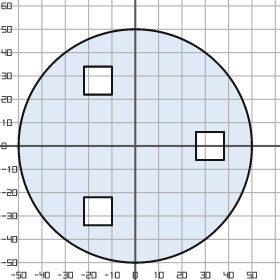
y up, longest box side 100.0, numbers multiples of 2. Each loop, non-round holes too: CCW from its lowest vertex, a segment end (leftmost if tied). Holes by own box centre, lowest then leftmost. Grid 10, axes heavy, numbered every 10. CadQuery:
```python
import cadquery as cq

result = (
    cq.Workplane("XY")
    .moveTo(0.0, 0.0)
    .circle(50.0)
    .moveTo(-22.0, -34.0)
    .lineTo(-10.0, -34.0)
    .lineTo(-10.0, -22.0)
    .lineTo(-22.0, -22.0)
    .close()
    .moveTo(26.0, -6.0)
    .lineTo(38.0, -6.0)
    .lineTo(38.0, 6.0)
    .lineTo(26.0, 6.0)
    .close()
    .moveTo(-22.0, 22.0)
    .lineTo(-10.0, 22.0)
    .lineTo(-10.0, 34.0)
    .lineTo(-22.0, 34.0)
    .close()
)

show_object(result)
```